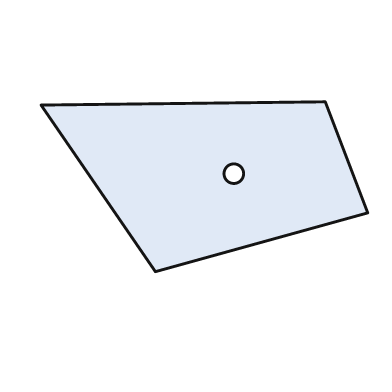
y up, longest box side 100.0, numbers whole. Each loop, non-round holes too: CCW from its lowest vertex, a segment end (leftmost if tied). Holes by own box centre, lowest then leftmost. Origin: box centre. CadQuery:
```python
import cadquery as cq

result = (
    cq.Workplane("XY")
    .moveTo(-15.0, -26.0)
    .lineTo(50.0, -8.0)
    .lineTo(37.0, 26.0)
    .lineTo(-50.0, 25.0)
    .close()
    .moveTo(9.0, 4.0)
    .circle(3.0)
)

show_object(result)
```